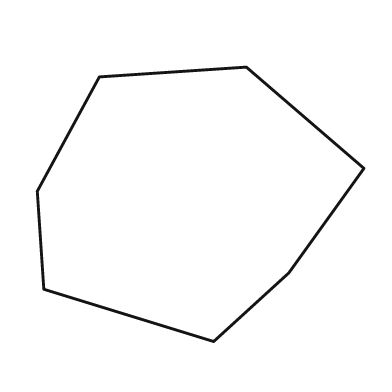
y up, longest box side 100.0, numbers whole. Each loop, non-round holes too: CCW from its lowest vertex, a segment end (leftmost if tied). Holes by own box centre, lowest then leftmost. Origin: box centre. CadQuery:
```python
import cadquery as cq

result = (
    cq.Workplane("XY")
    .moveTo(4.0, -42.0)
    .lineTo(27.0, -21.0)
    .lineTo(50.0, 11.0)
    .lineTo(14.0, 42.0)
    .lineTo(-31.0, 39.0)
    .lineTo(-50.0, 4.0)
    .lineTo(-48.0, -26.0)
    .close()
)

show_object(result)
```